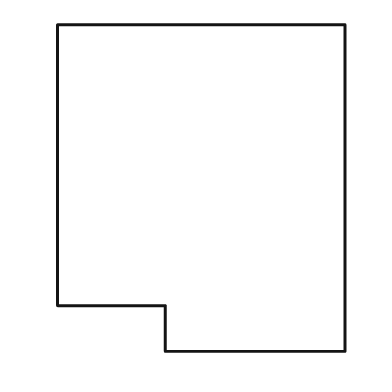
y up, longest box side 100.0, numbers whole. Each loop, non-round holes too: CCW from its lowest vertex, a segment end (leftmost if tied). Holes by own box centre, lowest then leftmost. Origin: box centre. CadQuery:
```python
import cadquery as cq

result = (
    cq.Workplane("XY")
    .moveTo(-11.0, -50.0)
    .lineTo(44.0, -50.0)
    .lineTo(44.0, 50.0)
    .lineTo(-44.0, 50.0)
    .lineTo(-44.0, -36.0)
    .lineTo(-11.0, -36.0)
    .close()
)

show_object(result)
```